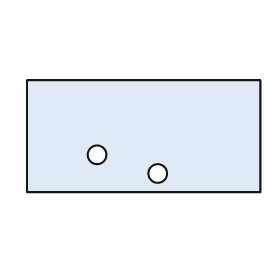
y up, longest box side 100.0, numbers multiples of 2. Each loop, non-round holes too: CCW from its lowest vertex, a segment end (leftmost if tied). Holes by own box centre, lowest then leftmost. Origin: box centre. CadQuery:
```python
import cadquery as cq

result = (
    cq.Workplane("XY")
    .moveTo(-50.0, -24.0)
    .lineTo(50.0, -24.0)
    .lineTo(50.0, 24.0)
    .lineTo(-50.0, 24.0)
    .close()
    .moveTo(6.0, -16.0)
    .circle(4.0)
    .moveTo(-20.0, -8.0)
    .circle(4.0)
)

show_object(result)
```